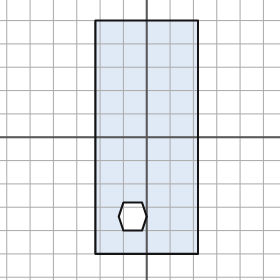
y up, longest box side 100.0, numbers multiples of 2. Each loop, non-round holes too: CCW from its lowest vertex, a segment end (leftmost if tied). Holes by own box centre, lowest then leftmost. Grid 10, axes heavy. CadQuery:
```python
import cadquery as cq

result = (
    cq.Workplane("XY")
    .moveTo(-22.0, -50.0)
    .lineTo(22.0, -50.0)
    .lineTo(22.0, 50.0)
    .lineTo(-22.0, 50.0)
    .close()
    .moveTo(-10.0, -40.0)
    .lineTo(-2.0, -40.0)
    .lineTo(0.0, -34.0)
    .lineTo(-2.0, -28.0)
    .lineTo(-10.0, -28.0)
    .lineTo(-12.0, -34.0)
    .close()
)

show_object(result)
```